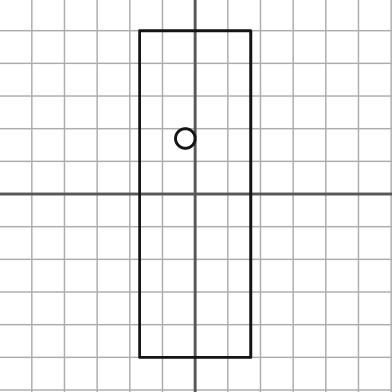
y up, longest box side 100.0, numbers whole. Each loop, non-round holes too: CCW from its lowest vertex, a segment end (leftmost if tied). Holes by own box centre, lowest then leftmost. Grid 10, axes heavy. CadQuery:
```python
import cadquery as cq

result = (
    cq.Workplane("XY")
    .moveTo(-17.0, -50.0)
    .lineTo(17.0, -50.0)
    .lineTo(17.0, 50.0)
    .lineTo(-17.0, 50.0)
    .close()
    .moveTo(-3.0, 17.0)
    .circle(3.0)
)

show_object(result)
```